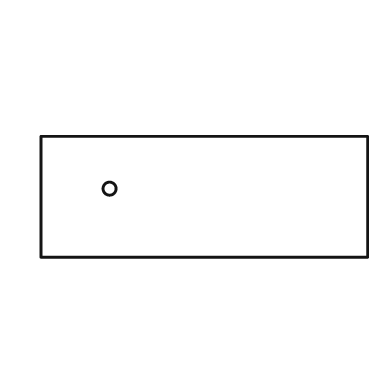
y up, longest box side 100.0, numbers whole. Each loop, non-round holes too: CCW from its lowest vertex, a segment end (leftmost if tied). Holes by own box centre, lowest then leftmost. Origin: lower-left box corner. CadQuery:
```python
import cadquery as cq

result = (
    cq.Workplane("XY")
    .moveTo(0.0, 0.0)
    .lineTo(100.0, 0.0)
    .lineTo(100.0, 37.0)
    .lineTo(0.0, 37.0)
    .close()
    .moveTo(21.0, 21.0)
    .circle(2.0)
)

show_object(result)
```